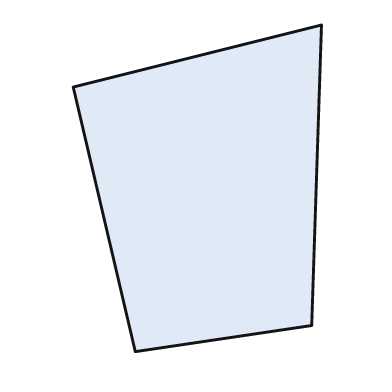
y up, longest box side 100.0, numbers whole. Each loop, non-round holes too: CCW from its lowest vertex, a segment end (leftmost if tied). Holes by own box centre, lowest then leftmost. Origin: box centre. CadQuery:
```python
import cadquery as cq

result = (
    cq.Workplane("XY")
    .moveTo(-19.0, -50.0)
    .lineTo(35.0, -42.0)
    .lineTo(38.0, 50.0)
    .lineTo(-38.0, 31.0)
    .close()
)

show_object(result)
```